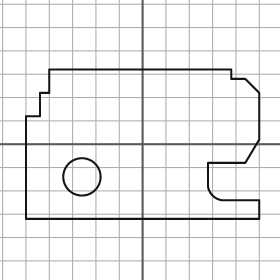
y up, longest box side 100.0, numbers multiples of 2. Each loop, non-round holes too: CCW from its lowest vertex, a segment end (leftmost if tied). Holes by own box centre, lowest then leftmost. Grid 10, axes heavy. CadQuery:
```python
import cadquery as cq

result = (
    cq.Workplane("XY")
    .moveTo(-50.0, -32.0)
    .lineTo(50.0, -32.0)
    .lineTo(50.0, -24.0)
    .lineTo(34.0, -24.0)
    .threePointArc((30.0, -22.0), (28.0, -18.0))
    .lineTo(28.0, -8.0)
    .lineTo(44.0, -8.0)
    .lineTo(50.0, 2.0)
    .lineTo(50.0, 22.0)
    .lineTo(44.0, 28.0)
    .lineTo(38.0, 28.0)
    .lineTo(38.0, 32.0)
    .lineTo(-40.0, 32.0)
    .lineTo(-40.0, 22.0)
    .lineTo(-44.0, 22.0)
    .lineTo(-44.0, 12.0)
    .lineTo(-50.0, 12.0)
    .close()
    .moveTo(-26.0, -14.0)
    .circle(8.0)
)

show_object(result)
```